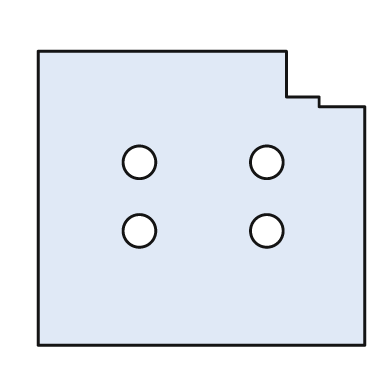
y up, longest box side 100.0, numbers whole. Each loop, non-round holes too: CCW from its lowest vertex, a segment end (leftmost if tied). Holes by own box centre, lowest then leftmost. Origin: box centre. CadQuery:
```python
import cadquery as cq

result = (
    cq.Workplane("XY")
    .moveTo(-50.0, -45.0)
    .lineTo(50.0, -45.0)
    .lineTo(50.0, 28.0)
    .lineTo(36.0, 28.0)
    .lineTo(36.0, 31.0)
    .lineTo(26.0, 31.0)
    .lineTo(26.0, 45.0)
    .lineTo(-50.0, 45.0)
    .close()
    .moveTo(-19.0, -10.0)
    .circle(5.0)
    .moveTo(20.0, -10.0)
    .circle(5.0)
    .moveTo(-19.0, 11.0)
    .circle(5.0)
    .moveTo(20.0, 11.0)
    .circle(5.0)
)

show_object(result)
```